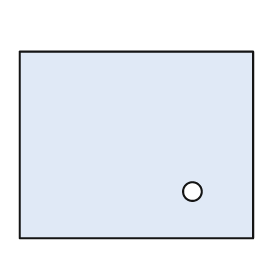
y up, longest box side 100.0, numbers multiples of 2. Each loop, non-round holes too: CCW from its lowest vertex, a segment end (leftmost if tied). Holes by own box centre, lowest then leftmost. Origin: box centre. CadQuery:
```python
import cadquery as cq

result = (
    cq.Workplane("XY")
    .moveTo(-50.0, -40.0)
    .lineTo(50.0, -40.0)
    .lineTo(50.0, 40.0)
    .lineTo(-50.0, 40.0)
    .close()
    .moveTo(24.0, -20.0)
    .circle(4.0)
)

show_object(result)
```